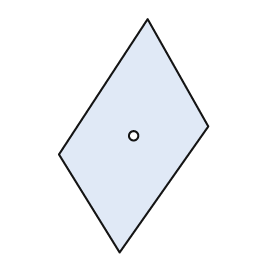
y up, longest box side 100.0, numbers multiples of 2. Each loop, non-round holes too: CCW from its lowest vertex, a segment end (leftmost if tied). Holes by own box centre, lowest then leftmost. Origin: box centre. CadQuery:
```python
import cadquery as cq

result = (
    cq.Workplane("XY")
    .moveTo(-6.0, -50.0)
    .lineTo(32.0, 4.0)
    .lineTo(6.0, 50.0)
    .lineTo(-32.0, -8.0)
    .close()
    .moveTo(0.0, 0.0)
    .circle(2.0)
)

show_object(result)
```